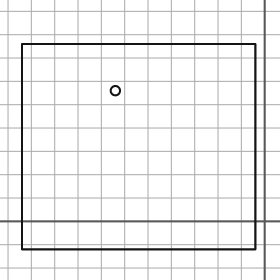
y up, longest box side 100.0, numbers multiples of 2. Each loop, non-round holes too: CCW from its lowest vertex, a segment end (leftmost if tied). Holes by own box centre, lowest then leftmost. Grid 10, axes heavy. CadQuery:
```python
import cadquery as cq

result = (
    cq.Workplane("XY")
    .moveTo(-104.0, -12.0)
    .lineTo(-4.0, -12.0)
    .lineTo(-4.0, 76.0)
    .lineTo(-104.0, 76.0)
    .close()
    .moveTo(-64.0, 56.0)
    .circle(2.0)
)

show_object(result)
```